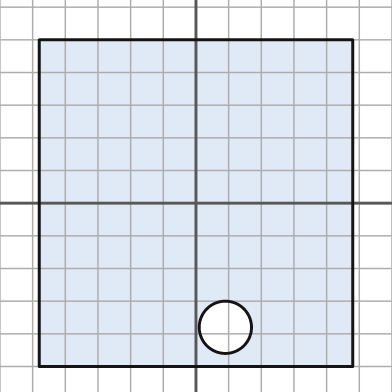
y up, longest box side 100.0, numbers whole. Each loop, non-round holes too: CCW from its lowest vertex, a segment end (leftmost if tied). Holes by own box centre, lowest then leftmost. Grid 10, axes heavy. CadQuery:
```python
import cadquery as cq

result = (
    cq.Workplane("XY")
    .moveTo(-48.0, -50.0)
    .lineTo(48.0, -50.0)
    .lineTo(48.0, 50.0)
    .lineTo(-48.0, 50.0)
    .close()
    .moveTo(9.0, -38.0)
    .circle(8.0)
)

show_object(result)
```